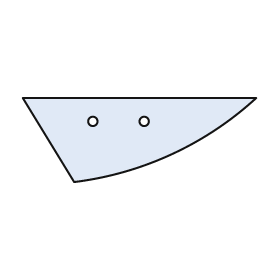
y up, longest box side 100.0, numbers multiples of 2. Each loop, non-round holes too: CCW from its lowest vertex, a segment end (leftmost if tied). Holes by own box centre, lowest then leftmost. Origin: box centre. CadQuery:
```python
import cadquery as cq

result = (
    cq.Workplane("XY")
    .moveTo(-28.0, -18.0)
    .threePointArc((14.0, -6.0), (50.0, 18.0))
    .lineTo(-50.0, 18.0)
    .close()
    .moveTo(-20.0, 8.0)
    .circle(2.0)
    .moveTo(2.0, 8.0)
    .circle(2.0)
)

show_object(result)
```